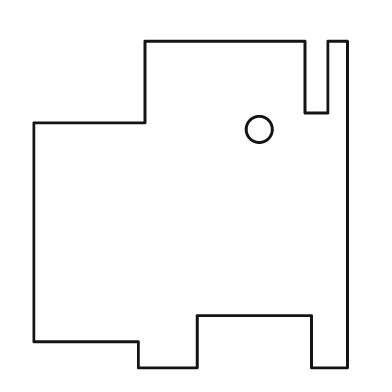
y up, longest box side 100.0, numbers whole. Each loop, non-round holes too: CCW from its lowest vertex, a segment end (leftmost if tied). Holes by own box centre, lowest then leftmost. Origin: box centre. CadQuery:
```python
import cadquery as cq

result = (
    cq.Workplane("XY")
    .moveTo(-16.0, -50.0)
    .lineTo(2.0, -50.0)
    .lineTo(2.0, -34.0)
    .lineTo(37.0, -34.0)
    .lineTo(37.0, -50.0)
    .lineTo(48.0, -50.0)
    .lineTo(48.0, 50.0)
    .lineTo(42.0, 50.0)
    .lineTo(42.0, 28.0)
    .lineTo(35.0, 28.0)
    .lineTo(35.0, 50.0)
    .lineTo(-14.0, 50.0)
    .lineTo(-14.0, 25.0)
    .lineTo(-48.0, 25.0)
    .lineTo(-48.0, -42.0)
    .lineTo(-16.0, -42.0)
    .close()
    .moveTo(21.0, 23.0)
    .circle(4.0)
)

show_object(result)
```